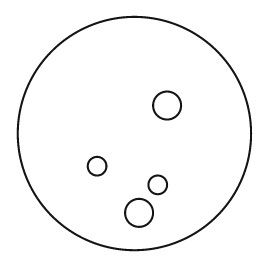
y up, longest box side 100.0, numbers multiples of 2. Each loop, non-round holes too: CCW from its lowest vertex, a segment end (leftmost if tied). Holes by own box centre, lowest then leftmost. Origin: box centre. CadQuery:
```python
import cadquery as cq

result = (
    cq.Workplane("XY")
    .moveTo(0.0, 0.0)
    .circle(50.0)
    .moveTo(2.0, -34.0)
    .circle(6.0)
    .moveTo(10.0, -22.0)
    .circle(4.0)
    .moveTo(-16.0, -14.0)
    .circle(4.0)
    .moveTo(14.0, 12.0)
    .circle(6.0)
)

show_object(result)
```